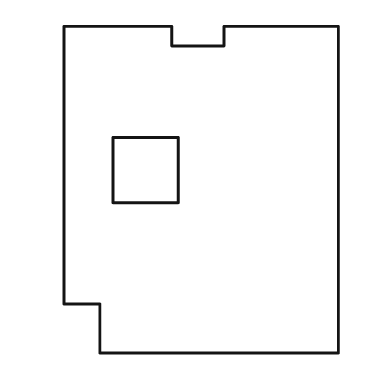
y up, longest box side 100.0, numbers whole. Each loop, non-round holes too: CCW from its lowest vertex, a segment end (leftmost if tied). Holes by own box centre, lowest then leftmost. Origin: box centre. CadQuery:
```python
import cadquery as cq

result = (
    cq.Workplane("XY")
    .moveTo(-31.0, -50.0)
    .lineTo(42.0, -50.0)
    .lineTo(42.0, 50.0)
    .lineTo(7.0, 50.0)
    .lineTo(7.0, 44.0)
    .lineTo(-9.0, 44.0)
    .lineTo(-9.0, 50.0)
    .lineTo(-42.0, 50.0)
    .lineTo(-42.0, -35.0)
    .lineTo(-31.0, -35.0)
    .close()
    .moveTo(-27.0, -4.0)
    .lineTo(-7.0, -4.0)
    .lineTo(-7.0, 16.0)
    .lineTo(-27.0, 16.0)
    .close()
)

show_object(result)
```